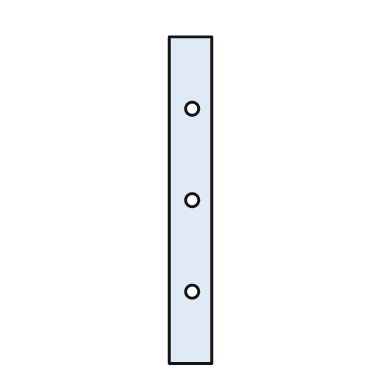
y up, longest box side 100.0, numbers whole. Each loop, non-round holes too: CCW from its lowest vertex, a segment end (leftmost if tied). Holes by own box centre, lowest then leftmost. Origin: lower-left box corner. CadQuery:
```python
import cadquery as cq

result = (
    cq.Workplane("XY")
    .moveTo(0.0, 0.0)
    .lineTo(13.0, 0.0)
    .lineTo(13.0, 100.0)
    .lineTo(0.0, 100.0)
    .close()
    .moveTo(7.0, 22.0)
    .circle(2.0)
    .moveTo(7.0, 50.0)
    .circle(2.0)
    .moveTo(7.0, 78.0)
    .circle(2.0)
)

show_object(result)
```